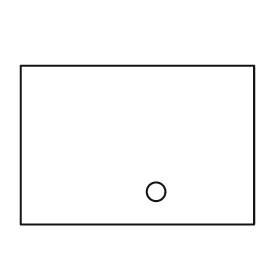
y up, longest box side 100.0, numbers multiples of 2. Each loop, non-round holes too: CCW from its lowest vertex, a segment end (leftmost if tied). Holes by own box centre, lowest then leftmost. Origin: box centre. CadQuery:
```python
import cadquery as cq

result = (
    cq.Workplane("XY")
    .moveTo(-50.0, -34.0)
    .lineTo(50.0, -34.0)
    .lineTo(50.0, 34.0)
    .lineTo(-50.0, 34.0)
    .close()
    .moveTo(8.0, -20.0)
    .circle(4.0)
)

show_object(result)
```